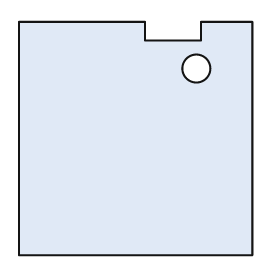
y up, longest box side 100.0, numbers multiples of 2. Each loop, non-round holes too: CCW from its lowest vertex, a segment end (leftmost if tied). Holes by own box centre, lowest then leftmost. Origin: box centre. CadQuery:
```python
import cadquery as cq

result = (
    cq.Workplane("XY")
    .moveTo(-50.0, -50.0)
    .lineTo(50.0, -50.0)
    .lineTo(50.0, 50.0)
    .lineTo(28.0, 50.0)
    .lineTo(28.0, 42.0)
    .lineTo(4.0, 42.0)
    .lineTo(4.0, 50.0)
    .lineTo(-50.0, 50.0)
    .close()
    .moveTo(26.0, 30.0)
    .circle(6.0)
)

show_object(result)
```